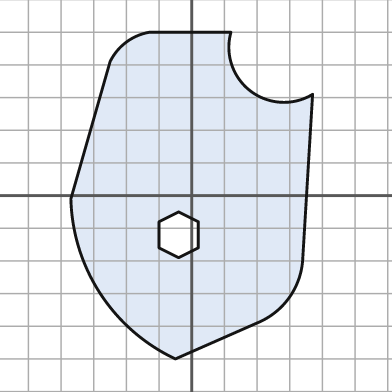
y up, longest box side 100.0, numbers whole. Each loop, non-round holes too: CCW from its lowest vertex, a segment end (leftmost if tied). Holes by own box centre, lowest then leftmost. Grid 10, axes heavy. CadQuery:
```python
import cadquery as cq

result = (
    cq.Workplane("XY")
    .moveTo(-5.0, -50.0)
    .lineTo(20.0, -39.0)
    .threePointArc((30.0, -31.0), (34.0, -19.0))
    .lineTo(37.0, 31.0)
    .threePointArc((18.0, 32.0), (12.0, 50.0))
    .lineTo(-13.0, 50.0)
    .threePointArc((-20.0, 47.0), (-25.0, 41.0))
    .lineTo(-37.0, -1.0)
    .threePointArc((-28.0, -30.0), (-5.0, -50.0))
    .close()
    .moveTo(-4.0, -19.0)
    .lineTo(2.0, -16.0)
    .lineTo(2.0, -8.0)
    .lineTo(-4.0, -5.0)
    .lineTo(-10.0, -8.0)
    .lineTo(-10.0, -16.0)
    .close()
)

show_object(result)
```